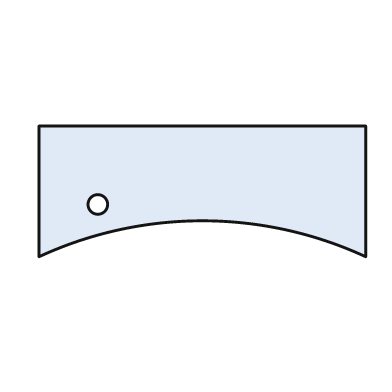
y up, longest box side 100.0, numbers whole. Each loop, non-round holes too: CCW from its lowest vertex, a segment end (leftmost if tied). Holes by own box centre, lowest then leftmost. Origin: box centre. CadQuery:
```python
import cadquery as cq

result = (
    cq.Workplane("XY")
    .moveTo(-50.0, -20.0)
    .threePointArc((0.0, -9.0), (50.0, -20.0))
    .lineTo(50.0, 20.0)
    .lineTo(-50.0, 20.0)
    .close()
    .moveTo(-32.0, -4.0)
    .circle(3.0)
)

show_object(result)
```